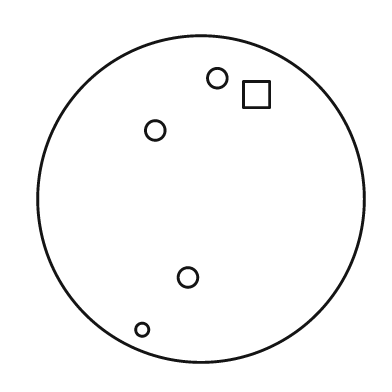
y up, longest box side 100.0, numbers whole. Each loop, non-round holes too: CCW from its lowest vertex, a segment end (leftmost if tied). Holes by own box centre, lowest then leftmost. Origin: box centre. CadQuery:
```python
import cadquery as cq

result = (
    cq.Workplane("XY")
    .moveTo(0.0, 0.0)
    .circle(50.0)
    .moveTo(-18.0, -40.0)
    .circle(2.0)
    .moveTo(-4.0, -24.0)
    .circle(3.0)
    .moveTo(-14.0, 21.0)
    .circle(3.0)
    .moveTo(13.0, 28.0)
    .lineTo(21.0, 28.0)
    .lineTo(21.0, 36.0)
    .lineTo(13.0, 36.0)
    .close()
    .moveTo(5.0, 37.0)
    .circle(3.0)
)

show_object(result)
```